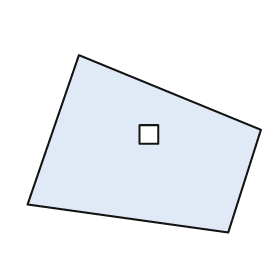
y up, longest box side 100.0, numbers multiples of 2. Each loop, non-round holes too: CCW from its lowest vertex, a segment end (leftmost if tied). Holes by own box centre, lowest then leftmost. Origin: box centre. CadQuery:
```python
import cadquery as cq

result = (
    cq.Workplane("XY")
    .moveTo(36.0, -38.0)
    .lineTo(50.0, 6.0)
    .lineTo(-28.0, 38.0)
    .lineTo(-50.0, -26.0)
    .close()
    .moveTo(-2.0, 0.0)
    .lineTo(6.0, 0.0)
    .lineTo(6.0, 8.0)
    .lineTo(-2.0, 8.0)
    .close()
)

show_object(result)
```